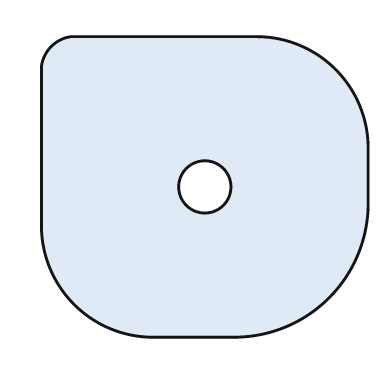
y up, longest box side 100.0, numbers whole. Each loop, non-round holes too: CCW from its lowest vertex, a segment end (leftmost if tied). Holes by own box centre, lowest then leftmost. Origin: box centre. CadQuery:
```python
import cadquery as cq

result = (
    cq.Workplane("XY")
    .moveTo(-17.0, -46.0)
    .lineTo(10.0, -46.0)
    .threePointArc((38.0, -34.0), (50.0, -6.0))
    .lineTo(50.0, 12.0)
    .threePointArc((40.0, 36.0), (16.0, 46.0))
    .lineTo(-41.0, 46.0)
    .threePointArc((-47.0, 43.0), (-50.0, 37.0))
    .lineTo(-50.0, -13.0)
    .threePointArc((-40.0, -36.0), (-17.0, -46.0))
    .close()
    .moveTo(0.0, 0.0)
    .circle(8.0)
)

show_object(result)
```